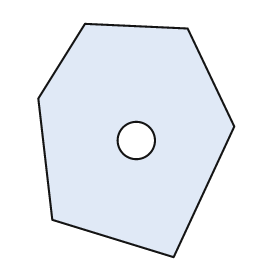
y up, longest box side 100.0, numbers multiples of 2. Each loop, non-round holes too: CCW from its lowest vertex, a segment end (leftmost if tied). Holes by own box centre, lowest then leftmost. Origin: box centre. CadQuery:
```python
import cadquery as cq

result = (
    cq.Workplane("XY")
    .moveTo(16.0, -50.0)
    .lineTo(42.0, 6.0)
    .lineTo(22.0, 48.0)
    .lineTo(-22.0, 50.0)
    .lineTo(-42.0, 18.0)
    .lineTo(-36.0, -34.0)
    .close()
    .moveTo(0.0, 0.0)
    .circle(8.0)
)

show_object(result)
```